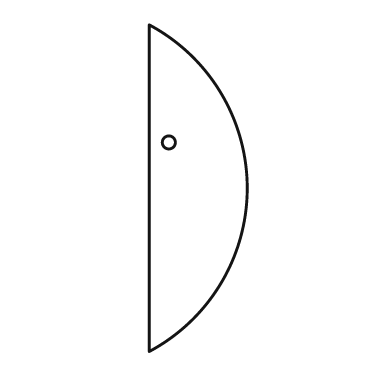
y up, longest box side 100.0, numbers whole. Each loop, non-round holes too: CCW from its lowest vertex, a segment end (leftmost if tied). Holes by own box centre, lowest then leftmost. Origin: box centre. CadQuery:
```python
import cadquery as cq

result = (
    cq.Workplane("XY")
    .moveTo(-15.0, -50.0)
    .threePointArc((15.0, 0.0), (-15.0, 50.0))
    .close()
    .moveTo(-9.0, 14.0)
    .circle(2.0)
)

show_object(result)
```